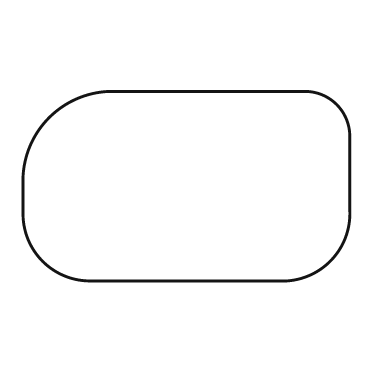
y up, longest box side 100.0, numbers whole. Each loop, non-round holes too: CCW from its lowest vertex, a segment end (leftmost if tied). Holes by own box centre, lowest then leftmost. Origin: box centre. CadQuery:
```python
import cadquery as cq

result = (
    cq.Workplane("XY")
    .moveTo(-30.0, -29.0)
    .lineTo(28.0, -29.0)
    .threePointArc((44.0, -23.0), (50.0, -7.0))
    .lineTo(50.0, 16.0)
    .threePointArc((46.0, 25.0), (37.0, 29.0))
    .lineTo(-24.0, 29.0)
    .threePointArc((-42.0, 21.0), (-50.0, 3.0))
    .lineTo(-50.0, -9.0)
    .threePointArc((-44.0, -23.0), (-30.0, -29.0))
    .close()
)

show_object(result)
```